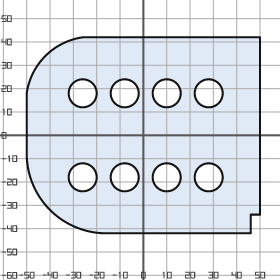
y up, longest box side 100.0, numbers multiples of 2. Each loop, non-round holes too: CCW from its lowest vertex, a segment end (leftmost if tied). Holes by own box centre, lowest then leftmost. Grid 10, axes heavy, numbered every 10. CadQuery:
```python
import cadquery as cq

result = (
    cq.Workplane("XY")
    .moveTo(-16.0, -42.0)
    .lineTo(46.0, -42.0)
    .lineTo(46.0, -34.0)
    .lineTo(50.0, -34.0)
    .lineTo(50.0, 42.0)
    .lineTo(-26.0, 42.0)
    .threePointArc((-42.0, 34.0), (-50.0, 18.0))
    .lineTo(-50.0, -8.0)
    .threePointArc((-40.0, -32.0), (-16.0, -42.0))
    .close()
    .moveTo(-26.0, -18.0)
    .circle(6.0)
    .moveTo(-8.0, -18.0)
    .circle(6.0)
    .moveTo(10.0, -18.0)
    .circle(6.0)
    .moveTo(28.0, -18.0)
    .circle(6.0)
    .moveTo(-26.0, 18.0)
    .circle(6.0)
    .moveTo(-8.0, 18.0)
    .circle(6.0)
    .moveTo(10.0, 18.0)
    .circle(6.0)
    .moveTo(28.0, 18.0)
    .circle(6.0)
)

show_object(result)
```